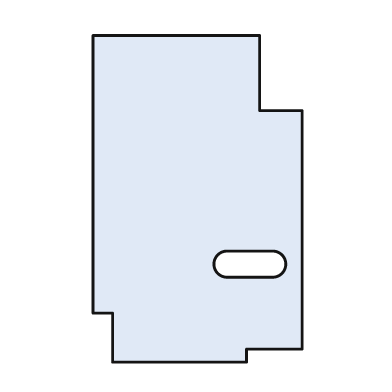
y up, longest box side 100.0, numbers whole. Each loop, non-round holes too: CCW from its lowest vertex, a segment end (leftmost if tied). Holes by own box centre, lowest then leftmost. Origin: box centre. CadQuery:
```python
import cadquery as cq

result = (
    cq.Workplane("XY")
    .moveTo(-26.0, -50.0)
    .lineTo(15.0, -50.0)
    .lineTo(15.0, -46.0)
    .lineTo(32.0, -46.0)
    .lineTo(32.0, 27.0)
    .lineTo(19.0, 27.0)
    .lineTo(19.0, 50.0)
    .lineTo(-32.0, 50.0)
    .lineTo(-32.0, -35.0)
    .lineTo(-26.0, -35.0)
    .close()
    .moveTo(9.0, -24.0)
    .lineTo(23.0, -24.0)
    .threePointArc((27.0, -20.0), (23.0, -16.0))
    .lineTo(9.0, -16.0)
    .threePointArc((5.0, -20.0), (9.0, -24.0))
    .close()
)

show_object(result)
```